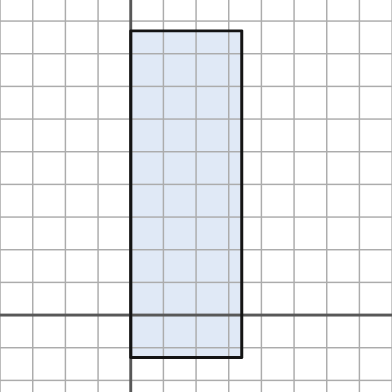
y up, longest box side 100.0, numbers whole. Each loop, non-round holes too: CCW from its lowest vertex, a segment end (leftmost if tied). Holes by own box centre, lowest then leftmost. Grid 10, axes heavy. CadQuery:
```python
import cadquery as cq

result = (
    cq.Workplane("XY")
    .moveTo(0.0, -13.0)
    .lineTo(34.0, -13.0)
    .lineTo(34.0, 87.0)
    .lineTo(0.0, 87.0)
    .close()
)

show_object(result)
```